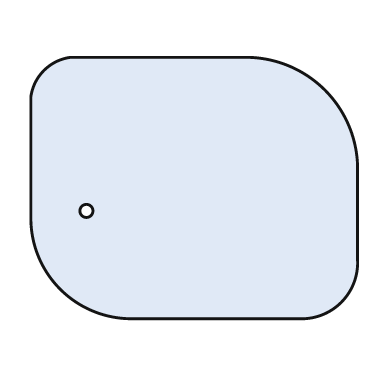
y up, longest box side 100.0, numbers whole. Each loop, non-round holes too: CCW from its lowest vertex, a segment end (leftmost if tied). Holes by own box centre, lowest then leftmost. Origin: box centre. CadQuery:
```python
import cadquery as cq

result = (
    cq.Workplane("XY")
    .moveTo(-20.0, -40.0)
    .lineTo(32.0, -40.0)
    .threePointArc((45.0, -35.0), (50.0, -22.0))
    .lineTo(50.0, 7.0)
    .threePointArc((40.0, 30.0), (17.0, 40.0))
    .lineTo(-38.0, 40.0)
    .threePointArc((-46.0, 36.0), (-50.0, 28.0))
    .lineTo(-50.0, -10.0)
    .threePointArc((-41.0, -31.0), (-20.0, -40.0))
    .close()
    .moveTo(-33.0, -7.0)
    .circle(2.0)
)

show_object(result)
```